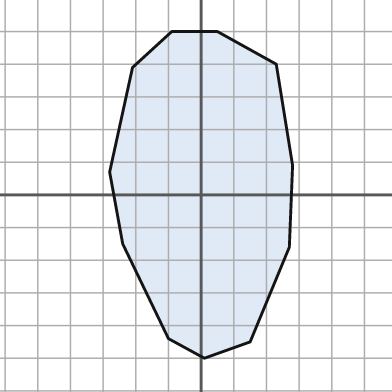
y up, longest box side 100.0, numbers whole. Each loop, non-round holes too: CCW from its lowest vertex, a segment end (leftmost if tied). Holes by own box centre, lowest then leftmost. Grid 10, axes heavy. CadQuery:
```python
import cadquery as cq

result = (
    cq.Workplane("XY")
    .moveTo(1.0, -50.0)
    .lineTo(15.0, -45.0)
    .lineTo(27.0, -16.0)
    .lineTo(28.0, 9.0)
    .lineTo(23.0, 40.0)
    .lineTo(5.0, 50.0)
    .lineTo(-9.0, 50.0)
    .lineTo(-21.0, 39.0)
    .lineTo(-28.0, 7.0)
    .lineTo(-24.0, -15.0)
    .lineTo(-10.0, -44.0)
    .close()
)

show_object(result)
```